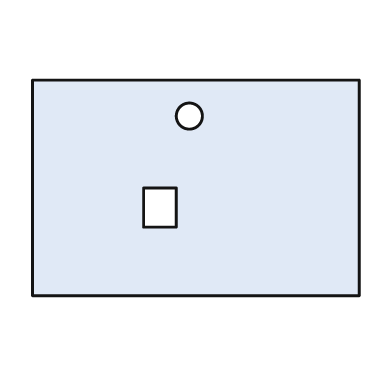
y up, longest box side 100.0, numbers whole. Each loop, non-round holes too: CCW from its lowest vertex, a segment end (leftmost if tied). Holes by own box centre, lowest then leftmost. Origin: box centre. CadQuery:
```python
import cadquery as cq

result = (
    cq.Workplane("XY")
    .moveTo(-50.0, -33.0)
    .lineTo(50.0, -33.0)
    .lineTo(50.0, 33.0)
    .lineTo(-50.0, 33.0)
    .close()
    .moveTo(-16.0, -12.0)
    .lineTo(-6.0, -12.0)
    .lineTo(-6.0, 0.0)
    .lineTo(-16.0, 0.0)
    .close()
    .moveTo(-2.0, 22.0)
    .circle(4.0)
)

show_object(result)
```